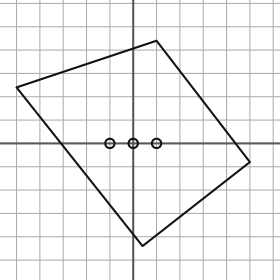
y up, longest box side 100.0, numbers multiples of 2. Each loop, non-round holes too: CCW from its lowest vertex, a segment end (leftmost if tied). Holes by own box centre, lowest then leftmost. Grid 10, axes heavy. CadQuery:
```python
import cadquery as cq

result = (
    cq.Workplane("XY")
    .moveTo(4.0, -44.0)
    .lineTo(50.0, -8.0)
    .lineTo(10.0, 44.0)
    .lineTo(-50.0, 24.0)
    .close()
    .moveTo(-10.0, 0.0)
    .circle(2.0)
    .moveTo(0.0, 0.0)
    .circle(2.0)
    .moveTo(10.0, 0.0)
    .circle(2.0)
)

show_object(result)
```